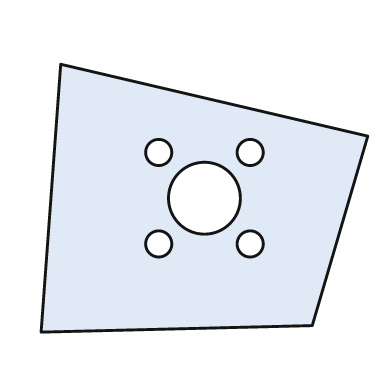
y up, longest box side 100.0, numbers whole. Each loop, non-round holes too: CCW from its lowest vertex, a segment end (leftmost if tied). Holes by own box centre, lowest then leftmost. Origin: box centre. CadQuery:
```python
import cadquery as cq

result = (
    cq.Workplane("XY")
    .moveTo(-50.0, -41.0)
    .lineTo(33.0, -39.0)
    .lineTo(50.0, 19.0)
    .lineTo(-44.0, 41.0)
    .close()
    .moveTo(-14.0, -14.0)
    .circle(4.0)
    .moveTo(14.0, -14.0)
    .circle(4.0)
    .moveTo(0.0, 0.0)
    .circle(11.0)
    .moveTo(-14.0, 14.0)
    .circle(4.0)
    .moveTo(14.0, 14.0)
    .circle(4.0)
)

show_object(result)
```